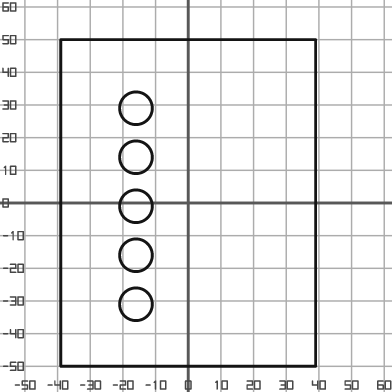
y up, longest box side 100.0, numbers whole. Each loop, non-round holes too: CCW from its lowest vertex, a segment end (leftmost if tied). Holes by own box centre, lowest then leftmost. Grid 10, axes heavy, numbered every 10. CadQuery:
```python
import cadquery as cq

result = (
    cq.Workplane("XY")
    .moveTo(-39.0, -50.0)
    .lineTo(39.0, -50.0)
    .lineTo(39.0, 50.0)
    .lineTo(-39.0, 50.0)
    .close()
    .moveTo(-16.0, -31.0)
    .circle(5.0)
    .moveTo(-16.0, -16.0)
    .circle(5.0)
    .moveTo(-16.0, -1.0)
    .circle(5.0)
    .moveTo(-16.0, 14.0)
    .circle(5.0)
    .moveTo(-16.0, 29.0)
    .circle(5.0)
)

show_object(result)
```